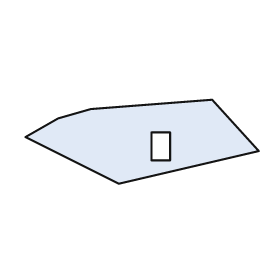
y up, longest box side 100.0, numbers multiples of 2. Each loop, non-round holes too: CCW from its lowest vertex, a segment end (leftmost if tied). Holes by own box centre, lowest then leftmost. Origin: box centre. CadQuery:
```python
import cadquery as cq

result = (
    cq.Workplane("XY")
    .moveTo(-10.0, -18.0)
    .lineTo(50.0, -4.0)
    .lineTo(30.0, 18.0)
    .lineTo(-22.0, 14.0)
    .lineTo(-36.0, 10.0)
    .lineTo(-50.0, 2.0)
    .close()
    .moveTo(4.0, -8.0)
    .lineTo(12.0, -8.0)
    .lineTo(12.0, 4.0)
    .lineTo(4.0, 4.0)
    .close()
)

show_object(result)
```